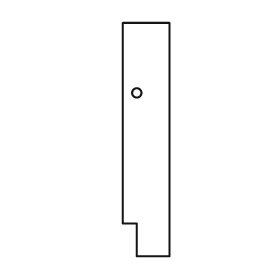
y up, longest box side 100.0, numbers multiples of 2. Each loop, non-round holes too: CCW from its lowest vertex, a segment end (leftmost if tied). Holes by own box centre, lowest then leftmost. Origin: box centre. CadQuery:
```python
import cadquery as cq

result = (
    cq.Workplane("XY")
    .moveTo(-4.0, -50.0)
    .lineTo(10.0, -50.0)
    .lineTo(10.0, 50.0)
    .lineTo(-10.0, 50.0)
    .lineTo(-10.0, -36.0)
    .lineTo(-4.0, -36.0)
    .close()
    .moveTo(-4.0, 20.0)
    .circle(2.0)
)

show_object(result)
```